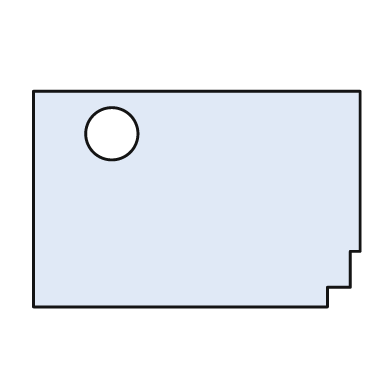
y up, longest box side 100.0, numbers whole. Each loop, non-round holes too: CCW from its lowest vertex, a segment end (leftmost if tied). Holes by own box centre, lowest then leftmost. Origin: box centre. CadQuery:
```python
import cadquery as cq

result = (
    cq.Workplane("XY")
    .moveTo(-50.0, -33.0)
    .lineTo(40.0, -33.0)
    .lineTo(40.0, -27.0)
    .lineTo(47.0, -27.0)
    .lineTo(47.0, -16.0)
    .lineTo(50.0, -16.0)
    .lineTo(50.0, 33.0)
    .lineTo(-50.0, 33.0)
    .close()
    .moveTo(-26.0, 20.0)
    .circle(8.0)
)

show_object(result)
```